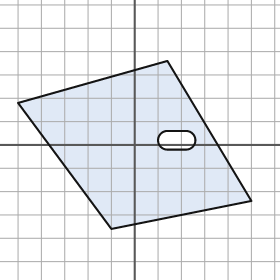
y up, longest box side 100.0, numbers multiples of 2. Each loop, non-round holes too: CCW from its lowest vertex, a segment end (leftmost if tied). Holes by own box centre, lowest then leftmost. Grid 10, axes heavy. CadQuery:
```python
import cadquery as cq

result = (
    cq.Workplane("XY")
    .moveTo(-10.0, -36.0)
    .lineTo(50.0, -24.0)
    .lineTo(14.0, 36.0)
    .lineTo(-50.0, 18.0)
    .close()
    .moveTo(14.0, -2.0)
    .lineTo(22.0, -2.0)
    .threePointArc((26.0, 2.0), (22.0, 6.0))
    .lineTo(14.0, 6.0)
    .threePointArc((10.0, 2.0), (14.0, -2.0))
    .close()
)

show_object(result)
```